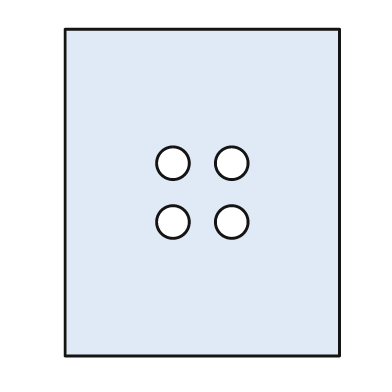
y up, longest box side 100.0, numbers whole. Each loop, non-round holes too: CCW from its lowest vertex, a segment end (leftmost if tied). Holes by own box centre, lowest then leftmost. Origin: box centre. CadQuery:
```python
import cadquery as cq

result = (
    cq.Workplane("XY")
    .moveTo(-42.0, -50.0)
    .lineTo(42.0, -50.0)
    .lineTo(42.0, 50.0)
    .lineTo(-42.0, 50.0)
    .close()
    .moveTo(-9.0, -9.0)
    .circle(5.0)
    .moveTo(9.0, -9.0)
    .circle(5.0)
    .moveTo(-9.0, 9.0)
    .circle(5.0)
    .moveTo(9.0, 9.0)
    .circle(5.0)
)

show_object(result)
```